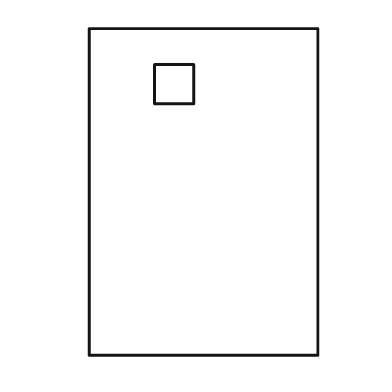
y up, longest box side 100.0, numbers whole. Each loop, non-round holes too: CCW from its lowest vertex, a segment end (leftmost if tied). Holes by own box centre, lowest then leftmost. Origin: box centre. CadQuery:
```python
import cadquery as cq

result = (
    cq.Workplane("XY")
    .moveTo(-35.0, -50.0)
    .lineTo(35.0, -50.0)
    .lineTo(35.0, 50.0)
    .lineTo(-35.0, 50.0)
    .close()
    .moveTo(-15.0, 27.0)
    .lineTo(-3.0, 27.0)
    .lineTo(-3.0, 39.0)
    .lineTo(-15.0, 39.0)
    .close()
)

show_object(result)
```